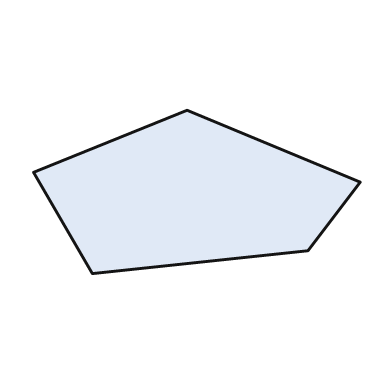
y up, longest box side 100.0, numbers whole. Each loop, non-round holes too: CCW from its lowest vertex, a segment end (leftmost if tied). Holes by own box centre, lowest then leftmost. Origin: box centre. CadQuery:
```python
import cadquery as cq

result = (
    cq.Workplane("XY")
    .moveTo(-32.0, -25.0)
    .lineTo(34.0, -18.0)
    .lineTo(50.0, 3.0)
    .lineTo(-3.0, 25.0)
    .lineTo(-50.0, 6.0)
    .close()
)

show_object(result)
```